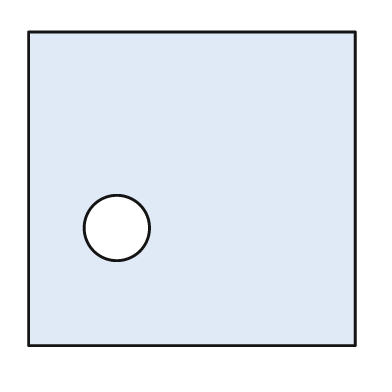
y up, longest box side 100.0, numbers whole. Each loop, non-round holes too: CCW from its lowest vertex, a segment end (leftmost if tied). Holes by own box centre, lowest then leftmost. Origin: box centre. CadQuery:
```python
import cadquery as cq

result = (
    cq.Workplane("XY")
    .moveTo(-50.0, -48.0)
    .lineTo(50.0, -48.0)
    .lineTo(50.0, 48.0)
    .lineTo(-50.0, 48.0)
    .close()
    .moveTo(-23.0, -12.0)
    .circle(10.0)
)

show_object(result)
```